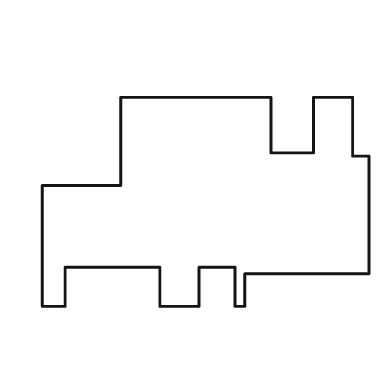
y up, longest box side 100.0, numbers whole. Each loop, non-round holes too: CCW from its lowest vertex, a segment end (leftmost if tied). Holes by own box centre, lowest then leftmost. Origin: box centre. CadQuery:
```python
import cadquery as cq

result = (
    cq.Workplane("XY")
    .moveTo(-50.0, -32.0)
    .lineTo(-43.0, -32.0)
    .lineTo(-43.0, -20.0)
    .lineTo(-14.0, -20.0)
    .lineTo(-14.0, -32.0)
    .lineTo(-2.0, -32.0)
    .lineTo(-2.0, -20.0)
    .lineTo(9.0, -20.0)
    .lineTo(9.0, -32.0)
    .lineTo(12.0, -32.0)
    .lineTo(12.0, -22.0)
    .lineTo(50.0, -22.0)
    .lineTo(50.0, 14.0)
    .lineTo(45.0, 14.0)
    .lineTo(45.0, 32.0)
    .lineTo(33.0, 32.0)
    .lineTo(33.0, 15.0)
    .lineTo(20.0, 15.0)
    .lineTo(20.0, 32.0)
    .lineTo(-26.0, 32.0)
    .lineTo(-26.0, 5.0)
    .lineTo(-50.0, 5.0)
    .close()
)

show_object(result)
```